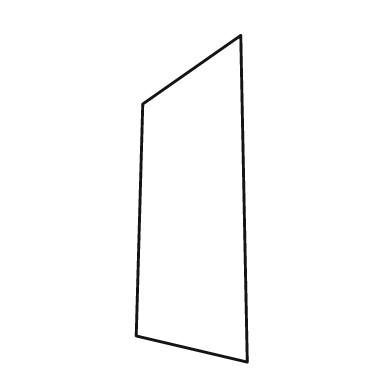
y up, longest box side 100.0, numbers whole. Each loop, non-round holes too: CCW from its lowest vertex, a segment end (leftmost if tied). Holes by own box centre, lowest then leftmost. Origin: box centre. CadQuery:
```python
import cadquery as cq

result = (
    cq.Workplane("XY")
    .moveTo(17.0, -50.0)
    .lineTo(15.0, 50.0)
    .lineTo(-15.0, 29.0)
    .lineTo(-17.0, -42.0)
    .close()
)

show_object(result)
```